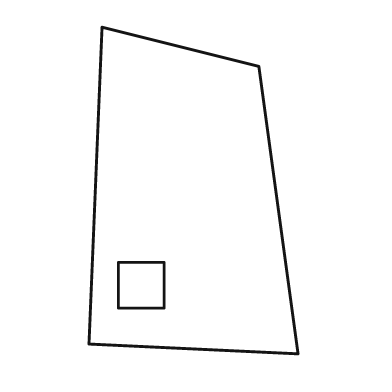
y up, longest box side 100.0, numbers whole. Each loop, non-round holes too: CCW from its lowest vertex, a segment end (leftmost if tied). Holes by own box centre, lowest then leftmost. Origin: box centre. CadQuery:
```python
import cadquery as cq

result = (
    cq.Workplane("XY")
    .moveTo(32.0, -50.0)
    .lineTo(20.0, 38.0)
    .lineTo(-28.0, 50.0)
    .lineTo(-32.0, -47.0)
    .close()
    .moveTo(-23.0, -36.0)
    .lineTo(-9.0, -36.0)
    .lineTo(-9.0, -22.0)
    .lineTo(-23.0, -22.0)
    .close()
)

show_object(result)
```